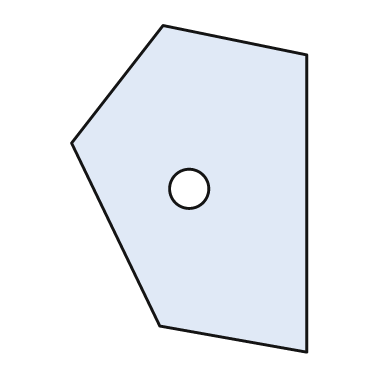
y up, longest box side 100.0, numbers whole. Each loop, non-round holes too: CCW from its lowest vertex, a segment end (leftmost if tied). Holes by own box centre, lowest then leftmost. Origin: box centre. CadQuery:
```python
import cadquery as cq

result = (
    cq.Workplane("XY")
    .moveTo(36.0, -50.0)
    .lineTo(36.0, 41.0)
    .lineTo(-8.0, 50.0)
    .lineTo(-36.0, 14.0)
    .lineTo(-9.0, -42.0)
    .close()
    .moveTo(0.0, 0.0)
    .circle(6.0)
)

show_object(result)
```